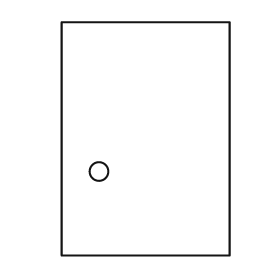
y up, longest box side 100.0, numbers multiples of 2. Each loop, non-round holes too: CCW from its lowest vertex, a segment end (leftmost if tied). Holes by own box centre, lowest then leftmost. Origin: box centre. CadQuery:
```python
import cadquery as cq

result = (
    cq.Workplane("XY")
    .moveTo(-36.0, -50.0)
    .lineTo(36.0, -50.0)
    .lineTo(36.0, 50.0)
    .lineTo(-36.0, 50.0)
    .close()
    .moveTo(-20.0, -14.0)
    .circle(4.0)
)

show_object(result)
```